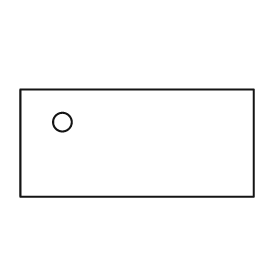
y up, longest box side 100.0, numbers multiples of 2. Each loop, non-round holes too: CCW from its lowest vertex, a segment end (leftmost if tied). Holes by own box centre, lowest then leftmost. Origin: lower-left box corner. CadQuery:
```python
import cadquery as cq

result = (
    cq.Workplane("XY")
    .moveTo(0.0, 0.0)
    .lineTo(100.0, 0.0)
    .lineTo(100.0, 46.0)
    .lineTo(0.0, 46.0)
    .close()
    .moveTo(18.0, 32.0)
    .circle(4.0)
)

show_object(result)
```